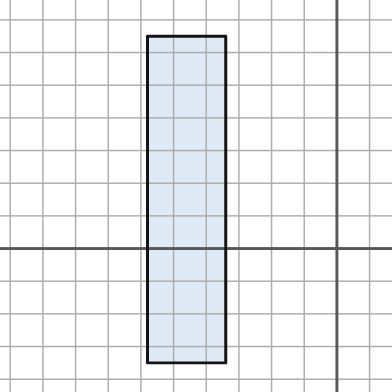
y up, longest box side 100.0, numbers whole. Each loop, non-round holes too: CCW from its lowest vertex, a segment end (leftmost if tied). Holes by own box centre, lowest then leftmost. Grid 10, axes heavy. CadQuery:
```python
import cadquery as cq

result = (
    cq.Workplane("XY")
    .moveTo(-58.0, -35.0)
    .lineTo(-34.0, -35.0)
    .lineTo(-34.0, 65.0)
    .lineTo(-58.0, 65.0)
    .close()
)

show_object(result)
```